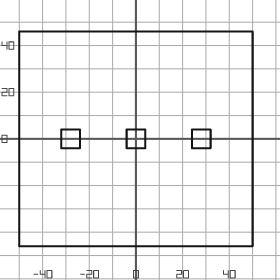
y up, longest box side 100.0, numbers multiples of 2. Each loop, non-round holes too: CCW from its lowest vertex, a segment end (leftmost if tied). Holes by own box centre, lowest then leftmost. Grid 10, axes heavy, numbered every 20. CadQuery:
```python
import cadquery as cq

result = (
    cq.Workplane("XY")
    .moveTo(-50.0, -46.0)
    .lineTo(50.0, -46.0)
    .lineTo(50.0, 46.0)
    .lineTo(-50.0, 46.0)
    .close()
    .moveTo(-32.0, -4.0)
    .lineTo(-24.0, -4.0)
    .lineTo(-24.0, 4.0)
    .lineTo(-32.0, 4.0)
    .close()
    .moveTo(-4.0, -4.0)
    .lineTo(4.0, -4.0)
    .lineTo(4.0, 4.0)
    .lineTo(-4.0, 4.0)
    .close()
    .moveTo(24.0, -4.0)
    .lineTo(32.0, -4.0)
    .lineTo(32.0, 4.0)
    .lineTo(24.0, 4.0)
    .close()
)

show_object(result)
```